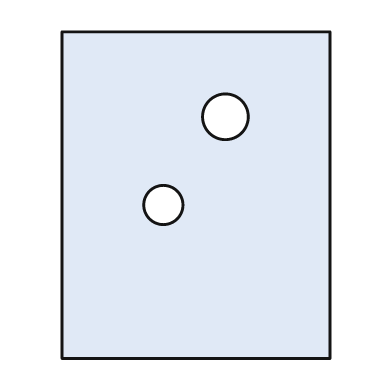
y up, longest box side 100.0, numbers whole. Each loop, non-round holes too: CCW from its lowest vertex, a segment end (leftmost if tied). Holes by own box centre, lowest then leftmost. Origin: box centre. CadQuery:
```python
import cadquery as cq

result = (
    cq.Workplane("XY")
    .moveTo(-41.0, -50.0)
    .lineTo(41.0, -50.0)
    .lineTo(41.0, 50.0)
    .lineTo(-41.0, 50.0)
    .close()
    .moveTo(-10.0, -3.0)
    .circle(6.0)
    .moveTo(9.0, 24.0)
    .circle(7.0)
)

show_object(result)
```